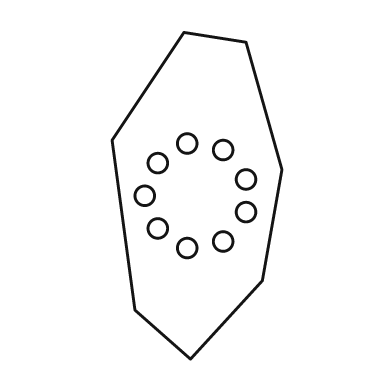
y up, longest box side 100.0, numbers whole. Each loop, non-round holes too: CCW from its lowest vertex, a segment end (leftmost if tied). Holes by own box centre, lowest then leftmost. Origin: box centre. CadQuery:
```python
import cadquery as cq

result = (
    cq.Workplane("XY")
    .moveTo(-2.0, -50.0)
    .lineTo(20.0, -26.0)
    .lineTo(26.0, 8.0)
    .lineTo(15.0, 47.0)
    .lineTo(-4.0, 50.0)
    .lineTo(-26.0, 17.0)
    .lineTo(-19.0, -35.0)
    .close()
    .moveTo(-3.0, -16.0)
    .circle(3.0)
    .moveTo(8.0, -14.0)
    .circle(3.0)
    .moveTo(-12.0, -10.0)
    .circle(3.0)
    .moveTo(15.0, -5.0)
    .circle(3.0)
    .moveTo(-16.0, 0.0)
    .circle(3.0)
    .moveTo(15.0, 5.0)
    .circle(3.0)
    .moveTo(-12.0, 10.0)
    .circle(3.0)
    .moveTo(8.0, 14.0)
    .circle(3.0)
    .moveTo(-3.0, 16.0)
    .circle(3.0)
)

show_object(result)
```